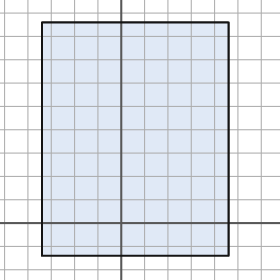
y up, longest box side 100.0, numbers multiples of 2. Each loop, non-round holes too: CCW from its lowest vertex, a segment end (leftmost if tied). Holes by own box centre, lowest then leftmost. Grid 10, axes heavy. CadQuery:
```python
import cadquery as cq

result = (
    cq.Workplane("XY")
    .moveTo(-34.0, -14.0)
    .lineTo(46.0, -14.0)
    .lineTo(46.0, 86.0)
    .lineTo(-34.0, 86.0)
    .close()
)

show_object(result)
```